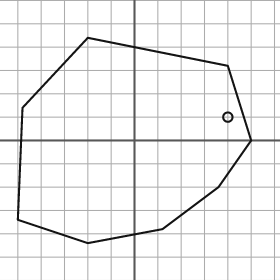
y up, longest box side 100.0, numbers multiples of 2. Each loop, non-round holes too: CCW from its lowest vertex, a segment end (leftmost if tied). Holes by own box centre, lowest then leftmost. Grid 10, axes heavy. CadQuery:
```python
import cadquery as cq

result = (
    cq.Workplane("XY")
    .moveTo(-20.0, -44.0)
    .lineTo(12.0, -38.0)
    .lineTo(36.0, -20.0)
    .lineTo(50.0, 0.0)
    .lineTo(40.0, 32.0)
    .lineTo(-20.0, 44.0)
    .lineTo(-48.0, 14.0)
    .lineTo(-50.0, -34.0)
    .close()
    .moveTo(40.0, 10.0)
    .circle(2.0)
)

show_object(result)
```